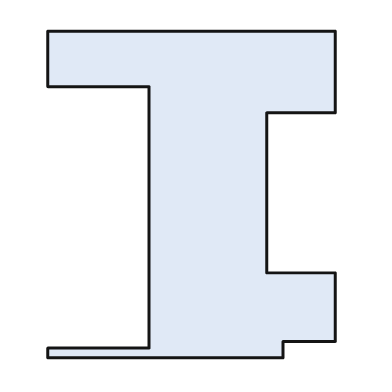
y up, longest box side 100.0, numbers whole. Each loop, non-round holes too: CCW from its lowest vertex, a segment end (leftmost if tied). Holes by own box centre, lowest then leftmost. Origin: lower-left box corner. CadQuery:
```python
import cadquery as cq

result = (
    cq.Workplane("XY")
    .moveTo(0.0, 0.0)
    .lineTo(72.0, 0.0)
    .lineTo(72.0, 5.0)
    .lineTo(88.0, 5.0)
    .lineTo(88.0, 26.0)
    .lineTo(67.0, 26.0)
    .lineTo(67.0, 75.0)
    .lineTo(88.0, 75.0)
    .lineTo(88.0, 100.0)
    .lineTo(0.0, 100.0)
    .lineTo(0.0, 83.0)
    .lineTo(31.0, 83.0)
    .lineTo(31.0, 3.0)
    .lineTo(0.0, 3.0)
    .close()
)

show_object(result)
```